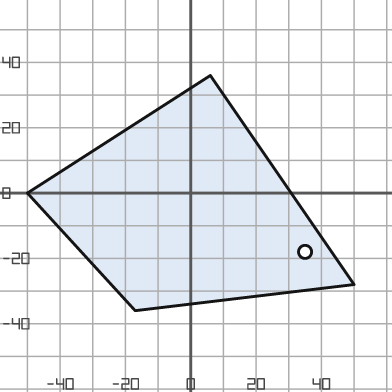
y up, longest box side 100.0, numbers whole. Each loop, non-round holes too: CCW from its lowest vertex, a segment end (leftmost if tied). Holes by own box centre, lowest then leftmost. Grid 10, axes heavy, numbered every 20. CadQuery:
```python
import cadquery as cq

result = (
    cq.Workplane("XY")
    .moveTo(-17.0, -36.0)
    .lineTo(50.0, -28.0)
    .lineTo(6.0, 36.0)
    .lineTo(-50.0, 0.0)
    .close()
    .moveTo(35.0, -18.0)
    .circle(2.0)
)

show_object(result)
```